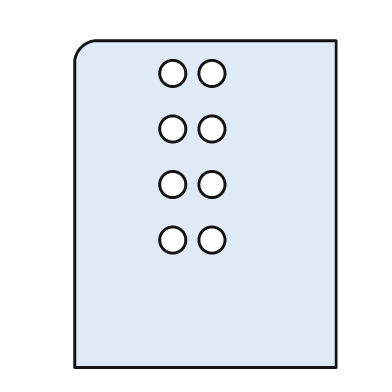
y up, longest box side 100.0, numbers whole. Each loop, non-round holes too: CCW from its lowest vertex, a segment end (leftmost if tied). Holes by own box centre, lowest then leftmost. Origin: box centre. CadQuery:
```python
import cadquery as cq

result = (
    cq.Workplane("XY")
    .moveTo(-40.0, -50.0)
    .lineTo(40.0, -50.0)
    .lineTo(40.0, 50.0)
    .lineTo(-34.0, 50.0)
    .threePointArc((-38.0, 48.0), (-40.0, 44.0))
    .close()
    .moveTo(-10.0, -11.0)
    .circle(4.0)
    .moveTo(2.0, -11.0)
    .circle(4.0)
    .moveTo(-10.0, 6.0)
    .circle(4.0)
    .moveTo(2.0, 6.0)
    .circle(4.0)
    .moveTo(-10.0, 23.0)
    .circle(4.0)
    .moveTo(2.0, 23.0)
    .circle(4.0)
    .moveTo(-10.0, 40.0)
    .circle(4.0)
    .moveTo(2.0, 40.0)
    .circle(4.0)
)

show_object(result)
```